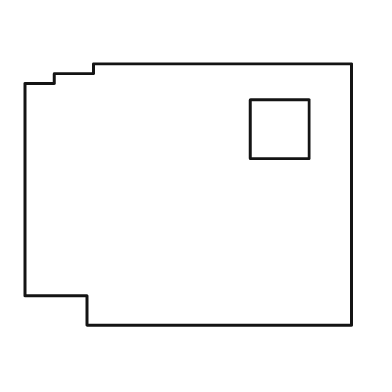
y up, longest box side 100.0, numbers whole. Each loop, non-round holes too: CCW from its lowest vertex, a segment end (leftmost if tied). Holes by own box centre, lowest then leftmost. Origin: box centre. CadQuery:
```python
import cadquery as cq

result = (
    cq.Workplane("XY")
    .moveTo(-31.0, -40.0)
    .lineTo(50.0, -40.0)
    .lineTo(50.0, 40.0)
    .lineTo(-29.0, 40.0)
    .lineTo(-29.0, 37.0)
    .lineTo(-41.0, 37.0)
    .lineTo(-41.0, 34.0)
    .lineTo(-50.0, 34.0)
    .lineTo(-50.0, -31.0)
    .lineTo(-31.0, -31.0)
    .close()
    .moveTo(19.0, 11.0)
    .lineTo(37.0, 11.0)
    .lineTo(37.0, 29.0)
    .lineTo(19.0, 29.0)
    .close()
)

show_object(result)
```